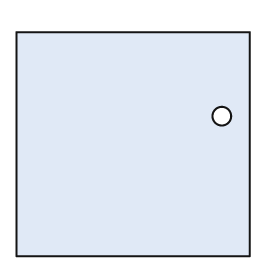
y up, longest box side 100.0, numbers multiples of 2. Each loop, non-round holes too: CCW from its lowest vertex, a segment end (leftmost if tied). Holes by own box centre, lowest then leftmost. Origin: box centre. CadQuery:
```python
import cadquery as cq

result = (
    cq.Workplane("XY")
    .moveTo(-50.0, -48.0)
    .lineTo(50.0, -48.0)
    .lineTo(50.0, 48.0)
    .lineTo(-50.0, 48.0)
    .close()
    .moveTo(38.0, 12.0)
    .circle(4.0)
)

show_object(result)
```